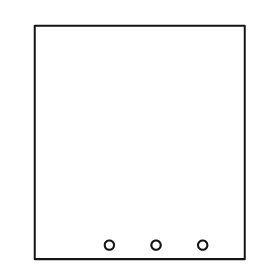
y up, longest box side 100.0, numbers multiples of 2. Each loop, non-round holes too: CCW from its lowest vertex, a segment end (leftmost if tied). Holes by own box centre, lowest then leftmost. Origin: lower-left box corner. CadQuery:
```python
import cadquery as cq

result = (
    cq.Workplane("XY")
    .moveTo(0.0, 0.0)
    .lineTo(90.0, 0.0)
    .lineTo(90.0, 100.0)
    .lineTo(0.0, 100.0)
    .close()
    .moveTo(32.0, 6.0)
    .circle(2.0)
    .moveTo(52.0, 6.0)
    .circle(2.0)
    .moveTo(72.0, 6.0)
    .circle(2.0)
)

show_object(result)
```